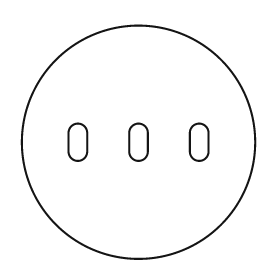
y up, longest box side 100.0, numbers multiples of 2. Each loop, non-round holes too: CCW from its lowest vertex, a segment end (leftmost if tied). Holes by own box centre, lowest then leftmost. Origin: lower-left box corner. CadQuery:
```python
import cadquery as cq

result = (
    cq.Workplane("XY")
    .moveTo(50.0, 50.0)
    .circle(50.0)
    .moveTo(20.0, 46.0)
    .threePointArc((24.0, 42.0), (28.0, 46.0))
    .lineTo(28.0, 54.0)
    .threePointArc((24.0, 58.0), (20.0, 54.0))
    .close()
    .moveTo(46.0, 46.0)
    .threePointArc((50.0, 42.0), (54.0, 46.0))
    .lineTo(54.0, 54.0)
    .threePointArc((50.0, 58.0), (46.0, 54.0))
    .close()
    .moveTo(72.0, 46.0)
    .threePointArc((76.0, 42.0), (80.0, 46.0))
    .lineTo(80.0, 54.0)
    .threePointArc((76.0, 58.0), (72.0, 54.0))
    .close()
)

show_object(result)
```